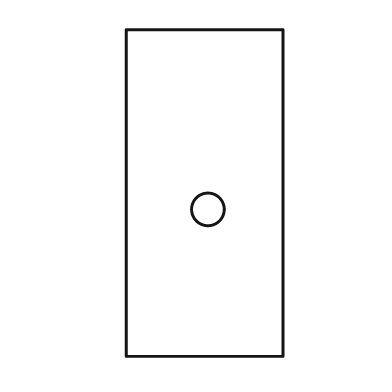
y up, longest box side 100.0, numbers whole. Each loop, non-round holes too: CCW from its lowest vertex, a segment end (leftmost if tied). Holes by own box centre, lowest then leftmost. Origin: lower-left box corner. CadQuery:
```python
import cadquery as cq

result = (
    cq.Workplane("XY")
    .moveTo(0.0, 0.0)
    .lineTo(48.0, 0.0)
    .lineTo(48.0, 100.0)
    .lineTo(0.0, 100.0)
    .close()
    .moveTo(25.0, 45.0)
    .circle(5.0)
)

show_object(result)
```